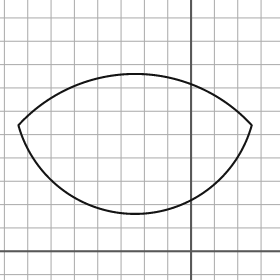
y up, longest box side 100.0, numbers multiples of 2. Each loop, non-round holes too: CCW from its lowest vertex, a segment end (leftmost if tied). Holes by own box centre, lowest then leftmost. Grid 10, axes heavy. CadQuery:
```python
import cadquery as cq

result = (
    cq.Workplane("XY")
    .moveTo(-74.0, 54.0)
    .threePointArc((-24.0, 16.0), (26.0, 54.0))
    .threePointArc((-24.0, 76.0), (-74.0, 54.0))
    .close()
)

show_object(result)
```